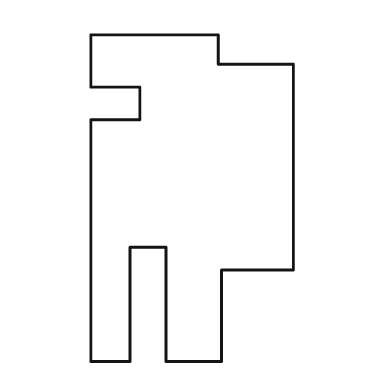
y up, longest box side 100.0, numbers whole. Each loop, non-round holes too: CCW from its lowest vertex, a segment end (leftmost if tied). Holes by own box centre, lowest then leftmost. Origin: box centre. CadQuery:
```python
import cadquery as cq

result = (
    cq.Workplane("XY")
    .moveTo(-31.0, -50.0)
    .lineTo(-19.0, -50.0)
    .lineTo(-19.0, -15.0)
    .lineTo(-8.0, -15.0)
    .lineTo(-8.0, -50.0)
    .lineTo(9.0, -50.0)
    .lineTo(9.0, -22.0)
    .lineTo(31.0, -22.0)
    .lineTo(31.0, 41.0)
    .lineTo(8.0, 41.0)
    .lineTo(8.0, 50.0)
    .lineTo(-31.0, 50.0)
    .lineTo(-31.0, 34.0)
    .lineTo(-16.0, 34.0)
    .lineTo(-16.0, 24.0)
    .lineTo(-31.0, 24.0)
    .close()
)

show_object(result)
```